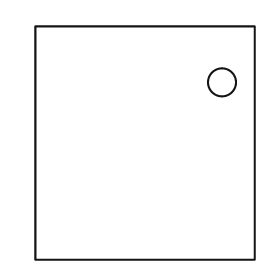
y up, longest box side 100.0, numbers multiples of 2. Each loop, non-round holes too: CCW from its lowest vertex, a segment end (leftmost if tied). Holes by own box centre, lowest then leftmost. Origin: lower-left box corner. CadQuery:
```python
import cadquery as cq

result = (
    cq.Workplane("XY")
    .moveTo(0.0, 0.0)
    .lineTo(94.0, 0.0)
    .lineTo(94.0, 100.0)
    .lineTo(0.0, 100.0)
    .close()
    .moveTo(80.0, 76.0)
    .circle(6.0)
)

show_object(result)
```